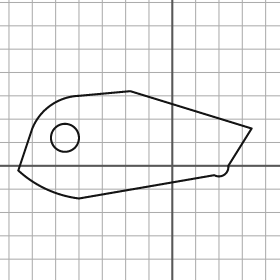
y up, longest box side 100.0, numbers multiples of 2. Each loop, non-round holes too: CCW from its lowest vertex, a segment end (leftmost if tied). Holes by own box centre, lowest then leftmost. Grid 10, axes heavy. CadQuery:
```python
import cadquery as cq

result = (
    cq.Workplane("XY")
    .moveTo(-40.0, -14.0)
    .lineTo(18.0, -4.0)
    .threePointArc((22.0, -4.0), (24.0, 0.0))
    .lineTo(34.0, 16.0)
    .lineTo(-18.0, 32.0)
    .lineTo(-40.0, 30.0)
    .threePointArc((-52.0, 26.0), (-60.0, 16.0))
    .lineTo(-66.0, -2.0)
    .threePointArc((-54.0, -10.0), (-40.0, -14.0))
    .close()
    .moveTo(-46.0, 12.0)
    .circle(6.0)
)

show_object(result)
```